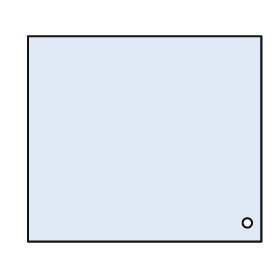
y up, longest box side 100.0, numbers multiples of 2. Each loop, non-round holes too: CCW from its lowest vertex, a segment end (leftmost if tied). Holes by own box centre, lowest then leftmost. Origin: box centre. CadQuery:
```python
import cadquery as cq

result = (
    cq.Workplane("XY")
    .moveTo(-50.0, -44.0)
    .lineTo(50.0, -44.0)
    .lineTo(50.0, 44.0)
    .lineTo(-50.0, 44.0)
    .close()
    .moveTo(44.0, -36.0)
    .circle(2.0)
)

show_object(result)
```